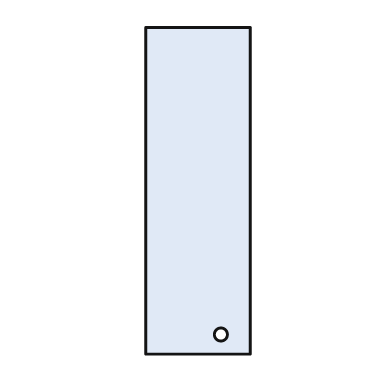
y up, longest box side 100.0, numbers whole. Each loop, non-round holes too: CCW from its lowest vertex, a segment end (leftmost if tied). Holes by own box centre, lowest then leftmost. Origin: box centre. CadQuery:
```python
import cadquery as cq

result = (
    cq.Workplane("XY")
    .moveTo(-16.0, -50.0)
    .lineTo(16.0, -50.0)
    .lineTo(16.0, 50.0)
    .lineTo(-16.0, 50.0)
    .close()
    .moveTo(7.0, -44.0)
    .circle(2.0)
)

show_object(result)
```